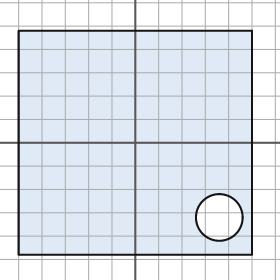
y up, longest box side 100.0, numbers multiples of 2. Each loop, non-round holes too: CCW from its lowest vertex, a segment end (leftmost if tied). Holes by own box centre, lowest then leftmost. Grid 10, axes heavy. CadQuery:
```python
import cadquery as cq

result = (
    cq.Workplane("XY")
    .moveTo(-50.0, -48.0)
    .lineTo(50.0, -48.0)
    .lineTo(50.0, 48.0)
    .lineTo(-50.0, 48.0)
    .close()
    .moveTo(36.0, -32.0)
    .circle(10.0)
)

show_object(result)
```